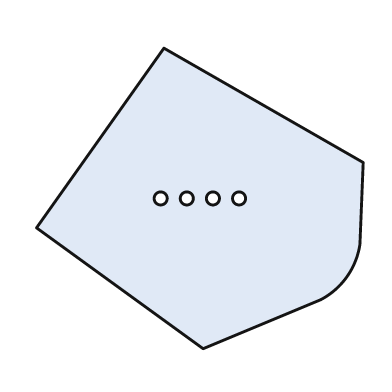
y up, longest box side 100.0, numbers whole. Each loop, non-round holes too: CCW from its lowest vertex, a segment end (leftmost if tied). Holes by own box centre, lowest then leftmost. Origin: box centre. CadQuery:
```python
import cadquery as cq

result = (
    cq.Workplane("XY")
    .moveTo(1.0, -46.0)
    .lineTo(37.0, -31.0)
    .threePointArc((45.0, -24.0), (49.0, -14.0))
    .lineTo(50.0, 11.0)
    .lineTo(-11.0, 46.0)
    .lineTo(-50.0, -9.0)
    .close()
    .moveTo(-12.0, 0.0)
    .circle(2.0)
    .moveTo(-4.0, 0.0)
    .circle(2.0)
    .moveTo(4.0, 0.0)
    .circle(2.0)
    .moveTo(12.0, 0.0)
    .circle(2.0)
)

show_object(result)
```